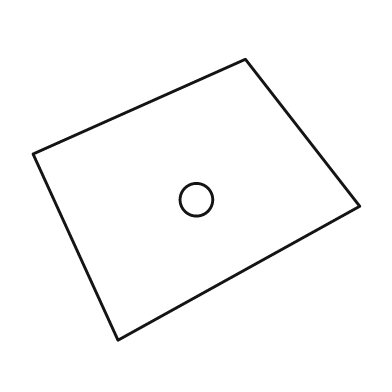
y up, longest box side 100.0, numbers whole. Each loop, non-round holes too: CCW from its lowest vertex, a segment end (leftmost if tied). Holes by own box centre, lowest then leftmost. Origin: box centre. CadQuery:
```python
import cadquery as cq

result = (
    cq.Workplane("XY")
    .moveTo(-24.0, -43.0)
    .lineTo(50.0, -2.0)
    .lineTo(15.0, 43.0)
    .lineTo(-50.0, 14.0)
    .close()
    .moveTo(0.0, 0.0)
    .circle(5.0)
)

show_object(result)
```